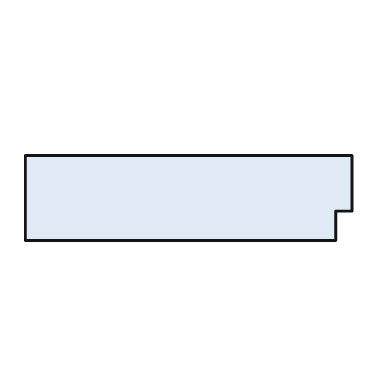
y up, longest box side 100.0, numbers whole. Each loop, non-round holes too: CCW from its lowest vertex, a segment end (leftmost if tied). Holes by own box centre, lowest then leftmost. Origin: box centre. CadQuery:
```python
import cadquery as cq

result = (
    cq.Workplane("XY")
    .moveTo(-50.0, -13.0)
    .lineTo(45.0, -13.0)
    .lineTo(45.0, -4.0)
    .lineTo(50.0, -4.0)
    .lineTo(50.0, 13.0)
    .lineTo(-50.0, 13.0)
    .close()
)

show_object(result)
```